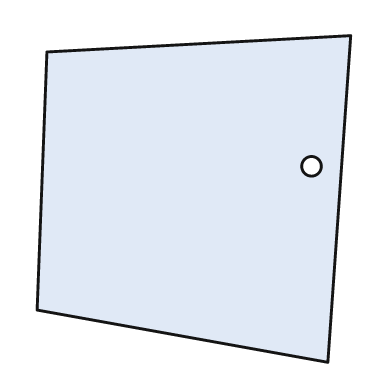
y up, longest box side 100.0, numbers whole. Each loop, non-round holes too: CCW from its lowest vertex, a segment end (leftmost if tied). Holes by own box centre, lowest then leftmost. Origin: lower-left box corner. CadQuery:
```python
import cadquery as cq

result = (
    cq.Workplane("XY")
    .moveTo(89.0, 0.0)
    .lineTo(96.0, 100.0)
    .lineTo(3.0, 95.0)
    .lineTo(0.0, 16.0)
    .close()
    .moveTo(84.0, 60.0)
    .circle(3.0)
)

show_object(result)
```